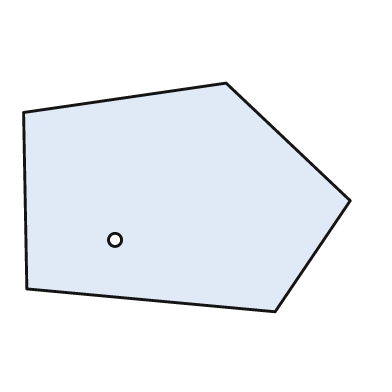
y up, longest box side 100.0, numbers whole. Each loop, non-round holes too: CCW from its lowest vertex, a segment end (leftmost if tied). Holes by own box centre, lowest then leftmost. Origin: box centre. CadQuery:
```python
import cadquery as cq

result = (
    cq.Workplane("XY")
    .moveTo(27.0, -35.0)
    .lineTo(50.0, -1.0)
    .lineTo(12.0, 35.0)
    .lineTo(-50.0, 26.0)
    .lineTo(-49.0, -28.0)
    .close()
    .moveTo(-22.0, -13.0)
    .circle(2.0)
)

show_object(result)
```